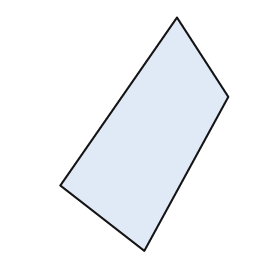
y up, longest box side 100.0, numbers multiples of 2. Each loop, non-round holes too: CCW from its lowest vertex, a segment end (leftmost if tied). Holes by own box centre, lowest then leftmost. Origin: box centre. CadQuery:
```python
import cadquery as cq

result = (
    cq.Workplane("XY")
    .moveTo(0.0, -50.0)
    .lineTo(36.0, 16.0)
    .lineTo(14.0, 50.0)
    .lineTo(-36.0, -22.0)
    .close()
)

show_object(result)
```